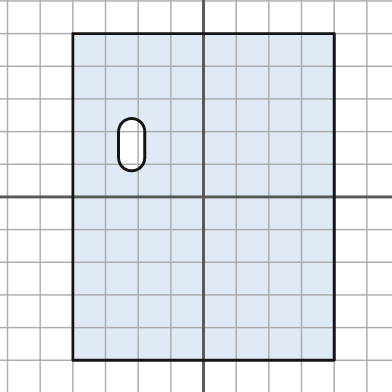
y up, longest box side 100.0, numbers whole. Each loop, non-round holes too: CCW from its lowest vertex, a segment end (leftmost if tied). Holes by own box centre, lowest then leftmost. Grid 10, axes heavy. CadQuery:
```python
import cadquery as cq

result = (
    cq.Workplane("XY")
    .moveTo(-40.0, -50.0)
    .lineTo(40.0, -50.0)
    .lineTo(40.0, 50.0)
    .lineTo(-40.0, 50.0)
    .close()
    .moveTo(-26.0, 12.0)
    .threePointArc((-22.0, 8.0), (-18.0, 12.0))
    .lineTo(-18.0, 20.0)
    .threePointArc((-22.0, 24.0), (-26.0, 20.0))
    .close()
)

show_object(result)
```